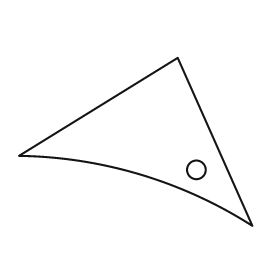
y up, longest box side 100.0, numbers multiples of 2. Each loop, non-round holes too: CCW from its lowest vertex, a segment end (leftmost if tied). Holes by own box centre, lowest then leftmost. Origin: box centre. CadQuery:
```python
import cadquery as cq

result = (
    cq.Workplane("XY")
    .moveTo(50.0, -36.0)
    .lineTo(18.0, 36.0)
    .lineTo(-50.0, -6.0)
    .threePointArc((2.0, -14.0), (50.0, -36.0))
    .close()
    .moveTo(26.0, -12.0)
    .circle(4.0)
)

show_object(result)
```